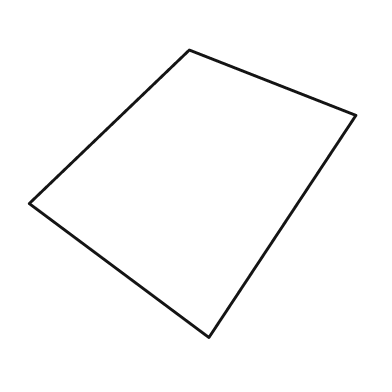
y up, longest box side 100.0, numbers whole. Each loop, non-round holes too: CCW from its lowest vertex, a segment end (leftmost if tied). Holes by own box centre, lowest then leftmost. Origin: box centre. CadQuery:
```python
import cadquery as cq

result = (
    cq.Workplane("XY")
    .moveTo(5.0, -44.0)
    .lineTo(50.0, 24.0)
    .lineTo(-1.0, 44.0)
    .lineTo(-50.0, -3.0)
    .close()
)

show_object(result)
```